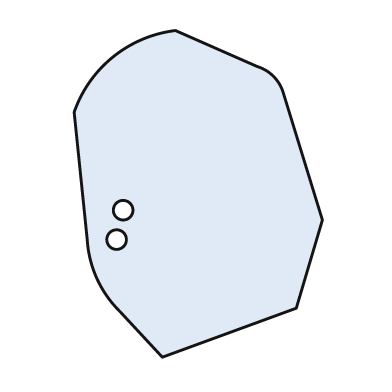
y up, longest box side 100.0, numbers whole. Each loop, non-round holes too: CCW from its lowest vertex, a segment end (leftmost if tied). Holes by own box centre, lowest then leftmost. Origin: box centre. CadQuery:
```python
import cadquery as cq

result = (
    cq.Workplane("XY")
    .moveTo(-11.0, -50.0)
    .lineTo(30.0, -35.0)
    .lineTo(38.0, -8.0)
    .lineTo(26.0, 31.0)
    .threePointArc((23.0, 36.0), (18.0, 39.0))
    .lineTo(-7.0, 50.0)
    .threePointArc((-26.0, 42.0), (-38.0, 25.0))
    .lineTo(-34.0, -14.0)
    .threePointArc((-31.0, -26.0), (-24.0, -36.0))
    .close()
    .moveTo(-25.0, -14.0)
    .circle(3.0)
    .moveTo(-23.0, -5.0)
    .circle(3.0)
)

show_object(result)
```